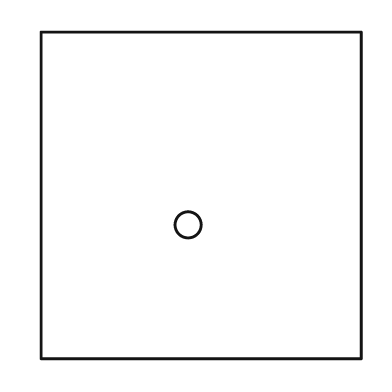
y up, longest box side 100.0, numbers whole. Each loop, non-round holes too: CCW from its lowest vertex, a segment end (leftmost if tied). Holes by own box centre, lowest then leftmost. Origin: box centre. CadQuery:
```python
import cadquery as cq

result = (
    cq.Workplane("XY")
    .moveTo(-49.0, -50.0)
    .lineTo(49.0, -50.0)
    .lineTo(49.0, 50.0)
    .lineTo(-49.0, 50.0)
    .close()
    .moveTo(-4.0, -9.0)
    .circle(4.0)
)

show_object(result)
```